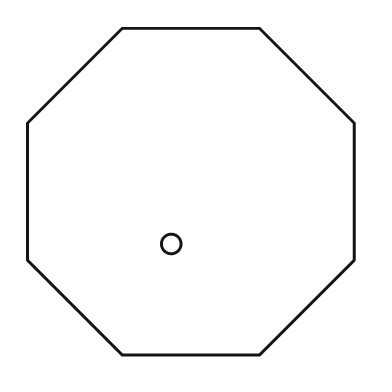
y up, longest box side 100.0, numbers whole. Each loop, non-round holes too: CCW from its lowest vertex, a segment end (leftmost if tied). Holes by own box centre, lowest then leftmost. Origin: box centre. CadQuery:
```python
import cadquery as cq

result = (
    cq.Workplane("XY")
    .moveTo(-21.0, -50.0)
    .lineTo(21.0, -50.0)
    .lineTo(50.0, -21.0)
    .lineTo(50.0, 21.0)
    .lineTo(21.0, 50.0)
    .lineTo(-21.0, 50.0)
    .lineTo(-50.0, 21.0)
    .lineTo(-50.0, -21.0)
    .close()
    .moveTo(-6.0, -16.0)
    .circle(3.0)
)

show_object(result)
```